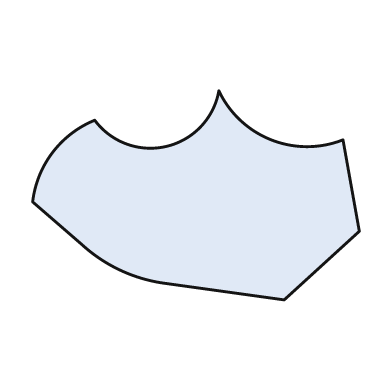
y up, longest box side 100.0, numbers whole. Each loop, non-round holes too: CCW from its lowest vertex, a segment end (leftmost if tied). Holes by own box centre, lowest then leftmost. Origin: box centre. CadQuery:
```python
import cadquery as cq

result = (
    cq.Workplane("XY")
    .moveTo(27.0, -32.0)
    .lineTo(50.0, -11.0)
    .lineTo(45.0, 17.0)
    .threePointArc((23.0, 17.0), (7.0, 32.0))
    .threePointArc((-9.0, 15.0), (-31.0, 23.0))
    .threePointArc((-44.0, 13.0), (-50.0, -2.0))
    .lineTo(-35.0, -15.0)
    .threePointArc((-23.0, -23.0), (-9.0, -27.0))
    .close()
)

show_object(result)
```